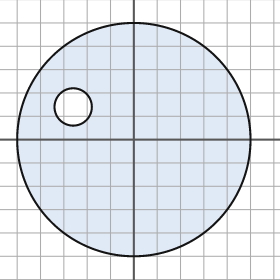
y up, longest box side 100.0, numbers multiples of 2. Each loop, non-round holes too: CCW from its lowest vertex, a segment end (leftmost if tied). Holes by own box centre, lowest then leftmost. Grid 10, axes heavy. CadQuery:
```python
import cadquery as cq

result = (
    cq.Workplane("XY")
    .moveTo(0.0, 0.0)
    .circle(50.0)
    .moveTo(-26.0, 14.0)
    .circle(8.0)
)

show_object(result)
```